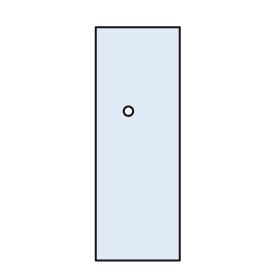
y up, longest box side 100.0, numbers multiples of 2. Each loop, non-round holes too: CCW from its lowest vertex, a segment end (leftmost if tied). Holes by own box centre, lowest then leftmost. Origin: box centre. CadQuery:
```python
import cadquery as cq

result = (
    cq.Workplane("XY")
    .moveTo(-18.0, -50.0)
    .lineTo(18.0, -50.0)
    .lineTo(18.0, 50.0)
    .lineTo(-18.0, 50.0)
    .close()
    .moveTo(-4.0, 14.0)
    .circle(2.0)
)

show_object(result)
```